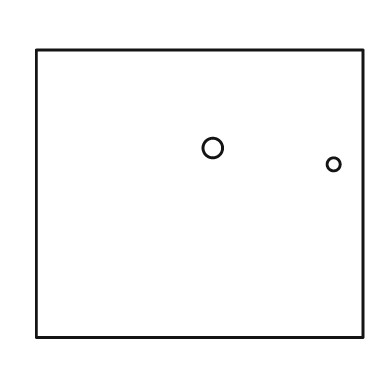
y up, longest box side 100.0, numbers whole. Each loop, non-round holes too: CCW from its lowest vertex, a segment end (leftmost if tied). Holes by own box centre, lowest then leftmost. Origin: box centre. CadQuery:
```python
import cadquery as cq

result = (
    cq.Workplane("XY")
    .moveTo(-50.0, -44.0)
    .lineTo(50.0, -44.0)
    .lineTo(50.0, 44.0)
    .lineTo(-50.0, 44.0)
    .close()
    .moveTo(41.0, 9.0)
    .circle(2.0)
    .moveTo(4.0, 14.0)
    .circle(3.0)
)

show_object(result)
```